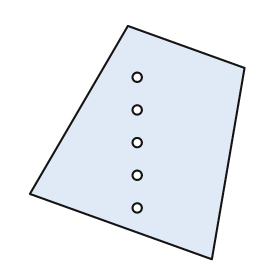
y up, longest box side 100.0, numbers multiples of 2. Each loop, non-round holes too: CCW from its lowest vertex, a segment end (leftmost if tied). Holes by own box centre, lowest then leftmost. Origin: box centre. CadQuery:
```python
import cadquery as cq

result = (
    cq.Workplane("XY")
    .moveTo(32.0, -50.0)
    .lineTo(46.0, 32.0)
    .lineTo(-4.0, 50.0)
    .lineTo(-46.0, -22.0)
    .close()
    .moveTo(0.0, -28.0)
    .circle(2.0)
    .moveTo(0.0, -14.0)
    .circle(2.0)
    .moveTo(0.0, 0.0)
    .circle(2.0)
    .moveTo(0.0, 14.0)
    .circle(2.0)
    .moveTo(0.0, 28.0)
    .circle(2.0)
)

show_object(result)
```